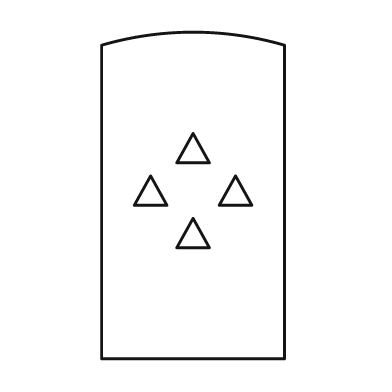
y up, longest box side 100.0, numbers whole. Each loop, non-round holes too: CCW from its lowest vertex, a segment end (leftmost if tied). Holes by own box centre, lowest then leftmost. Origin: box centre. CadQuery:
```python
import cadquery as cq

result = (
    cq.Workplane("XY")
    .moveTo(-28.0, -50.0)
    .lineTo(28.0, -50.0)
    .lineTo(28.0, 46.0)
    .threePointArc((0.0, 50.0), (-28.0, 46.0))
    .close()
    .moveTo(-5.0, -16.0)
    .lineTo(5.0, -16.0)
    .lineTo(0.0, -7.0)
    .close()
    .moveTo(-18.0, -3.0)
    .lineTo(-8.0, -3.0)
    .lineTo(-13.0, 6.0)
    .close()
    .moveTo(8.0, -3.0)
    .lineTo(18.0, -3.0)
    .lineTo(13.0, 6.0)
    .close()
    .moveTo(-5.0, 10.0)
    .lineTo(5.0, 10.0)
    .lineTo(0.0, 19.0)
    .close()
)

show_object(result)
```